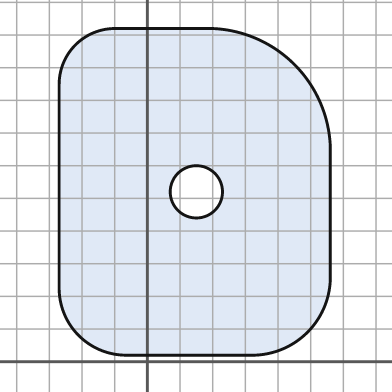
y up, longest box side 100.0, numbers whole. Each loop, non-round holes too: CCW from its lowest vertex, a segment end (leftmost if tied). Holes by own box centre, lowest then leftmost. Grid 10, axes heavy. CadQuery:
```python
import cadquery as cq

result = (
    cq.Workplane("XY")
    .moveTo(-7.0, 2.0)
    .lineTo(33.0, 2.0)
    .threePointArc((49.0, 9.0), (56.0, 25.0))
    .lineTo(56.0, 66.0)
    .threePointArc((45.0, 91.0), (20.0, 102.0))
    .lineTo(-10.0, 102.0)
    .threePointArc((-22.0, 97.0), (-27.0, 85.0))
    .lineTo(-27.0, 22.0)
    .threePointArc((-21.0, 8.0), (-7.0, 2.0))
    .close()
    .moveTo(15.0, 52.0)
    .circle(8.0)
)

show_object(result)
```